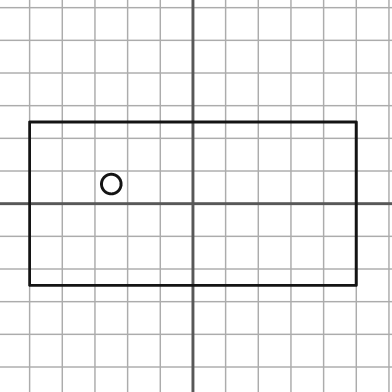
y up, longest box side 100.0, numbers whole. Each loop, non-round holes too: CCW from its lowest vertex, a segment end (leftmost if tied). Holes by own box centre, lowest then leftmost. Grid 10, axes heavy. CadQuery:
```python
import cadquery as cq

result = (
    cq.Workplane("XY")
    .moveTo(-50.0, -25.0)
    .lineTo(50.0, -25.0)
    .lineTo(50.0, 25.0)
    .lineTo(-50.0, 25.0)
    .close()
    .moveTo(-25.0, 6.0)
    .circle(3.0)
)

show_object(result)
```